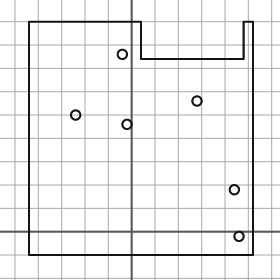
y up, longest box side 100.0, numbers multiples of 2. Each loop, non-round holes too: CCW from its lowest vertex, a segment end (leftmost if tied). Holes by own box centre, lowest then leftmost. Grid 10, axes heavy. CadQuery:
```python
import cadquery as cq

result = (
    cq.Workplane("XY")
    .moveTo(-44.0, -10.0)
    .lineTo(52.0, -10.0)
    .lineTo(52.0, 90.0)
    .lineTo(48.0, 90.0)
    .lineTo(48.0, 74.0)
    .lineTo(4.0, 74.0)
    .lineTo(4.0, 90.0)
    .lineTo(-44.0, 90.0)
    .close()
    .moveTo(46.0, -2.0)
    .circle(2.0)
    .moveTo(44.0, 18.0)
    .circle(2.0)
    .moveTo(-2.0, 46.0)
    .circle(2.0)
    .moveTo(-24.0, 50.0)
    .circle(2.0)
    .moveTo(28.0, 56.0)
    .circle(2.0)
    .moveTo(-4.0, 76.0)
    .circle(2.0)
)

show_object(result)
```